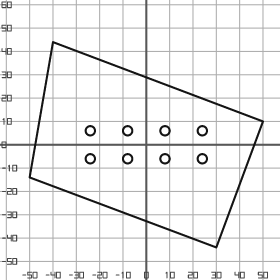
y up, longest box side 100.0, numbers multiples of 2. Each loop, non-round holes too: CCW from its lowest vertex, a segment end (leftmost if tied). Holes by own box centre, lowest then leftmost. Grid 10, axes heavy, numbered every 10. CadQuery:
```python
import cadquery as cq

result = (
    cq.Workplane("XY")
    .moveTo(30.0, -44.0)
    .lineTo(50.0, 10.0)
    .lineTo(-40.0, 44.0)
    .lineTo(-50.0, -14.0)
    .close()
    .moveTo(-24.0, -6.0)
    .circle(2.0)
    .moveTo(-8.0, -6.0)
    .circle(2.0)
    .moveTo(8.0, -6.0)
    .circle(2.0)
    .moveTo(24.0, -6.0)
    .circle(2.0)
    .moveTo(-24.0, 6.0)
    .circle(2.0)
    .moveTo(-8.0, 6.0)
    .circle(2.0)
    .moveTo(8.0, 6.0)
    .circle(2.0)
    .moveTo(24.0, 6.0)
    .circle(2.0)
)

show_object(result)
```